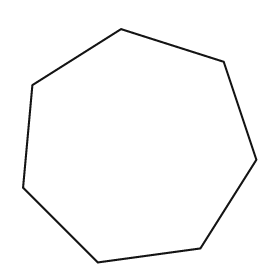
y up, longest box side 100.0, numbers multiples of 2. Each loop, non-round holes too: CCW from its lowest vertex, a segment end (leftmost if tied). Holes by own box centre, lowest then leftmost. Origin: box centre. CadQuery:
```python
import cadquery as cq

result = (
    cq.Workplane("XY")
    .moveTo(-18.0, -50.0)
    .lineTo(26.0, -44.0)
    .lineTo(50.0, -6.0)
    .lineTo(36.0, 36.0)
    .lineTo(-8.0, 50.0)
    .lineTo(-46.0, 26.0)
    .lineTo(-50.0, -18.0)
    .close()
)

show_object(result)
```